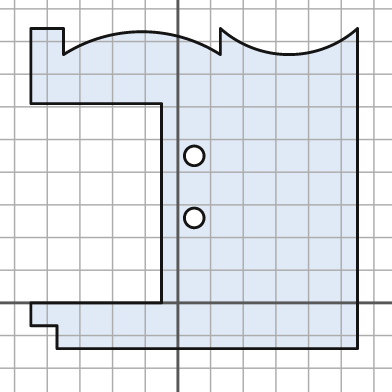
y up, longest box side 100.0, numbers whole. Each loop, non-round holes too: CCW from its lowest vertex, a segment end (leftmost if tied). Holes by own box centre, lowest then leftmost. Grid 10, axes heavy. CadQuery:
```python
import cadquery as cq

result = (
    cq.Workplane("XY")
    .moveTo(-37.0, -14.0)
    .lineTo(55.0, -14.0)
    .lineTo(55.0, 84.0)
    .threePointArc((34.0, 76.0), (13.0, 84.0))
    .lineTo(13.0, 76.0)
    .threePointArc((-11.0, 83.0), (-35.0, 76.0))
    .lineTo(-35.0, 84.0)
    .lineTo(-45.0, 84.0)
    .lineTo(-45.0, 61.0)
    .lineTo(-5.0, 61.0)
    .lineTo(-5.0, 0.0)
    .lineTo(-45.0, 0.0)
    .lineTo(-45.0, -7.0)
    .lineTo(-37.0, -7.0)
    .close()
    .moveTo(5.0, 26.0)
    .circle(3.0)
    .moveTo(5.0, 45.0)
    .circle(3.0)
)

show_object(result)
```